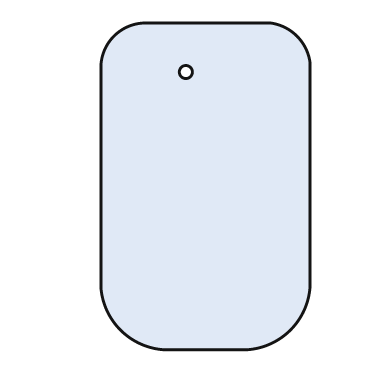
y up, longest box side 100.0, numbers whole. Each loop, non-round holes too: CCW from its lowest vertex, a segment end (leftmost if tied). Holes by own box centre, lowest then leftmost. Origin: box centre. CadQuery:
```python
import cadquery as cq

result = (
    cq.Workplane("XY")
    .moveTo(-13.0, -50.0)
    .lineTo(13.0, -50.0)
    .threePointArc((26.0, -44.0), (32.0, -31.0))
    .lineTo(32.0, 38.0)
    .threePointArc((28.0, 46.0), (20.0, 50.0))
    .lineTo(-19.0, 50.0)
    .threePointArc((-28.0, 46.0), (-32.0, 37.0))
    .lineTo(-32.0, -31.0)
    .threePointArc((-26.0, -44.0), (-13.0, -50.0))
    .close()
    .moveTo(-6.0, 35.0)
    .circle(2.0)
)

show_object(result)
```